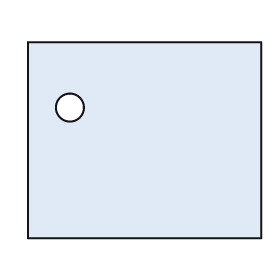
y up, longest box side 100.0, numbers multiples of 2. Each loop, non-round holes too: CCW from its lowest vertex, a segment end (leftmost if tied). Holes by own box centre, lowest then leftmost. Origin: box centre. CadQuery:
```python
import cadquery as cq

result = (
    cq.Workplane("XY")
    .moveTo(-50.0, -42.0)
    .lineTo(50.0, -42.0)
    .lineTo(50.0, 42.0)
    .lineTo(-50.0, 42.0)
    .close()
    .moveTo(-32.0, 14.0)
    .circle(6.0)
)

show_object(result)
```